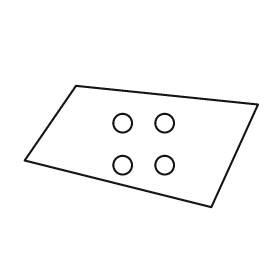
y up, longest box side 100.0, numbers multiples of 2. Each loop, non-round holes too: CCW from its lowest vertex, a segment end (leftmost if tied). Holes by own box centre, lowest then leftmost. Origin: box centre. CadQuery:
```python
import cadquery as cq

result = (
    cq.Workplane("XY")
    .moveTo(30.0, -26.0)
    .lineTo(50.0, 18.0)
    .lineTo(-28.0, 26.0)
    .lineTo(-50.0, -6.0)
    .close()
    .moveTo(-8.0, -8.0)
    .circle(4.0)
    .moveTo(10.0, -8.0)
    .circle(4.0)
    .moveTo(-8.0, 10.0)
    .circle(4.0)
    .moveTo(10.0, 10.0)
    .circle(4.0)
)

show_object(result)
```